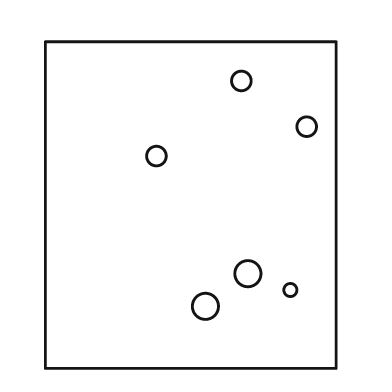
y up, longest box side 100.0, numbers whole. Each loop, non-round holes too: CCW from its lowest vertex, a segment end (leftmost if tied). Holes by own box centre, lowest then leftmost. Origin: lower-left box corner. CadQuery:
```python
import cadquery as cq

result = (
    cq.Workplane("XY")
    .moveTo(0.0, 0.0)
    .lineTo(89.0, 0.0)
    .lineTo(89.0, 100.0)
    .lineTo(0.0, 100.0)
    .close()
    .moveTo(49.0, 19.0)
    .circle(4.0)
    .moveTo(75.0, 24.0)
    .circle(2.0)
    .moveTo(62.0, 29.0)
    .circle(4.0)
    .moveTo(34.0, 65.0)
    .circle(3.0)
    .moveTo(80.0, 74.0)
    .circle(3.0)
    .moveTo(60.0, 88.0)
    .circle(3.0)
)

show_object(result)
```